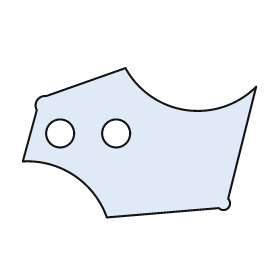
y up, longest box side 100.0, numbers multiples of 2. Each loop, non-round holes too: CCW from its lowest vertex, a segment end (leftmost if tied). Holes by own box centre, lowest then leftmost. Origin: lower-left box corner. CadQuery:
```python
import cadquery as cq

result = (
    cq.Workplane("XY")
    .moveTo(36.0, 0.0)
    .lineTo(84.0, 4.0)
    .threePointArc((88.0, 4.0), (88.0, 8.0))
    .lineTo(100.0, 56.0)
    .threePointArc((70.0, 46.0), (44.0, 64.0))
    .lineTo(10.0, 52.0)
    .threePointArc((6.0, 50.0), (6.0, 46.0))
    .lineTo(0.0, 24.0)
    .threePointArc((22.0, 18.0), (36.0, 0.0))
    .close()
    .moveTo(16.0, 36.0)
    .circle(6.0)
    .moveTo(40.0, 36.0)
    .circle(6.0)
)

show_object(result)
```